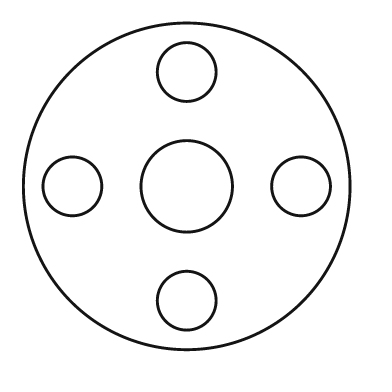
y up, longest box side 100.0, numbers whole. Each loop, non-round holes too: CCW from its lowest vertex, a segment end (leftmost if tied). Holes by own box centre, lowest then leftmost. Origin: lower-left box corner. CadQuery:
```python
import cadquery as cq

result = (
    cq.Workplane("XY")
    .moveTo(50.0, 50.0)
    .circle(50.0)
    .moveTo(50.0, 15.0)
    .circle(9.0)
    .moveTo(15.0, 50.0)
    .circle(9.0)
    .moveTo(50.0, 50.0)
    .circle(14.0)
    .moveTo(85.0, 50.0)
    .circle(9.0)
    .moveTo(50.0, 85.0)
    .circle(9.0)
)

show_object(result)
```